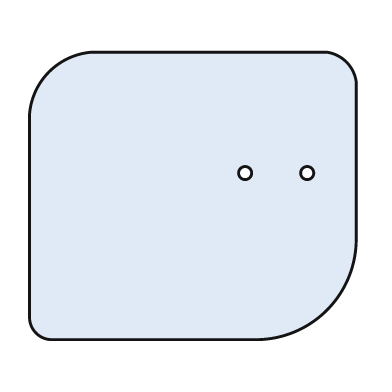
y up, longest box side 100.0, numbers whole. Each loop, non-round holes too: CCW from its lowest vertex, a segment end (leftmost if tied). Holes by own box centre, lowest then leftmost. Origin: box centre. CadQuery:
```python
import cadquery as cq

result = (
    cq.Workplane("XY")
    .moveTo(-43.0, -44.0)
    .lineTo(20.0, -44.0)
    .threePointArc((41.0, -35.0), (50.0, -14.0))
    .lineTo(50.0, 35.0)
    .threePointArc((47.0, 41.0), (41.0, 44.0))
    .lineTo(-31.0, 44.0)
    .threePointArc((-44.0, 38.0), (-50.0, 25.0))
    .lineTo(-50.0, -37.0)
    .threePointArc((-48.0, -42.0), (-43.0, -44.0))
    .close()
    .moveTo(16.0, 7.0)
    .circle(2.0)
    .moveTo(35.0, 7.0)
    .circle(2.0)
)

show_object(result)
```